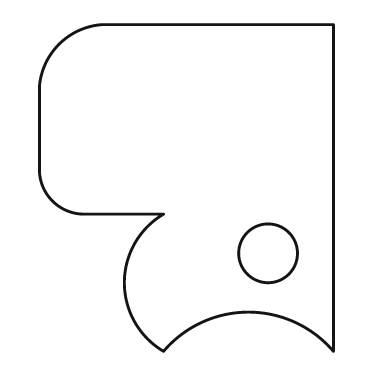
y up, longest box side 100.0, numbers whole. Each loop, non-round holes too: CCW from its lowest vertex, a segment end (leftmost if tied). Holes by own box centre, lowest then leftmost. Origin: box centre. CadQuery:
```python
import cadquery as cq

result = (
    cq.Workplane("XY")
    .moveTo(-7.0, -50.0)
    .threePointArc((19.0, -38.0), (45.0, -50.0))
    .lineTo(45.0, 50.0)
    .lineTo(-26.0, 50.0)
    .threePointArc((-39.0, 44.0), (-45.0, 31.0))
    .lineTo(-45.0, 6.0)
    .threePointArc((-41.0, -4.0), (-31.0, -8.0))
    .lineTo(-7.0, -8.0)
    .threePointArc((-19.0, -29.0), (-7.0, -50.0))
    .close()
    .moveTo(25.0, -20.0)
    .circle(9.0)
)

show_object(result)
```